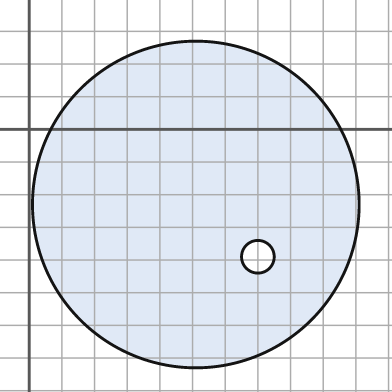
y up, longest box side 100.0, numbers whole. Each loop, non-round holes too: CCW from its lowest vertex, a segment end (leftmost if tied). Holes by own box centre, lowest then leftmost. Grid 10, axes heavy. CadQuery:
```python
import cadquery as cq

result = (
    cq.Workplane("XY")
    .moveTo(51.0, -23.0)
    .circle(50.0)
    .moveTo(70.0, -39.0)
    .circle(5.0)
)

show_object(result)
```